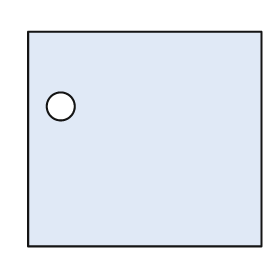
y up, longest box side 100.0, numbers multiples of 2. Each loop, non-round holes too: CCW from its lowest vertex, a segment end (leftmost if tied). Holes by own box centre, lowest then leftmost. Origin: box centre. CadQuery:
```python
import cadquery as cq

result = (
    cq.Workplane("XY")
    .moveTo(-50.0, -46.0)
    .lineTo(50.0, -46.0)
    .lineTo(50.0, 46.0)
    .lineTo(-50.0, 46.0)
    .close()
    .moveTo(-36.0, 14.0)
    .circle(6.0)
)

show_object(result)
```